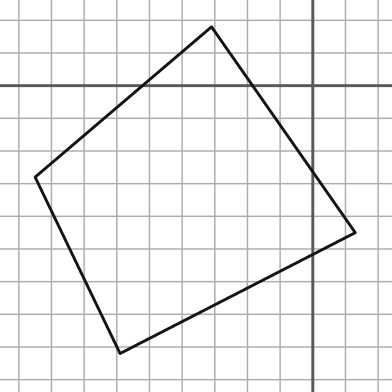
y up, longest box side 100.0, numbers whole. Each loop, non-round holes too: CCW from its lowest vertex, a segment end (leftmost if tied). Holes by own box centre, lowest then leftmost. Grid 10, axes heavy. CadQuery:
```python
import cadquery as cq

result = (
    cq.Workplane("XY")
    .moveTo(-59.0, -82.0)
    .lineTo(13.0, -45.0)
    .lineTo(-31.0, 18.0)
    .lineTo(-85.0, -28.0)
    .close()
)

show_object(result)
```